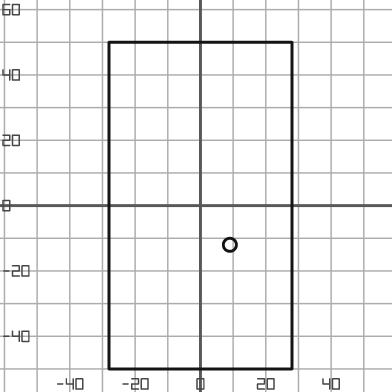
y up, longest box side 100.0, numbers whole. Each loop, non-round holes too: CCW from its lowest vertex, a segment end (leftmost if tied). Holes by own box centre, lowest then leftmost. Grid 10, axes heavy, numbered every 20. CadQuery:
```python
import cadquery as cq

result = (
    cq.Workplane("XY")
    .moveTo(-28.0, -50.0)
    .lineTo(28.0, -50.0)
    .lineTo(28.0, 50.0)
    .lineTo(-28.0, 50.0)
    .close()
    .moveTo(9.0, -12.0)
    .circle(2.0)
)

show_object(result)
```